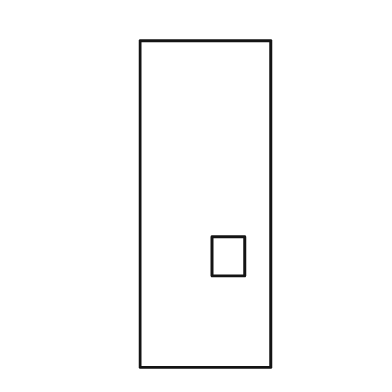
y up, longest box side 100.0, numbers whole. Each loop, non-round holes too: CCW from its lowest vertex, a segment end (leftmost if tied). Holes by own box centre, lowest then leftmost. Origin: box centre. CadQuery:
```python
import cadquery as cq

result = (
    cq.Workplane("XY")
    .moveTo(-20.0, -50.0)
    .lineTo(20.0, -50.0)
    .lineTo(20.0, 50.0)
    .lineTo(-20.0, 50.0)
    .close()
    .moveTo(2.0, -22.0)
    .lineTo(12.0, -22.0)
    .lineTo(12.0, -10.0)
    .lineTo(2.0, -10.0)
    .close()
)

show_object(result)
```